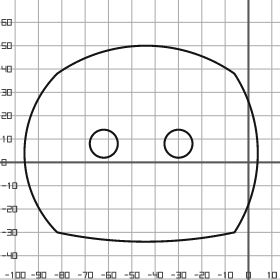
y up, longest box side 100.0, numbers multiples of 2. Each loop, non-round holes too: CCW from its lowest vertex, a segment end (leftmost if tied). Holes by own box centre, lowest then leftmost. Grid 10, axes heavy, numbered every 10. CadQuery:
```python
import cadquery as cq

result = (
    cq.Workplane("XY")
    .moveTo(-82.0, -30.0)
    .threePointArc((-44.0, -34.0), (-6.0, -30.0))
    .threePointArc((4.0, 4.0), (-6.0, 38.0))
    .threePointArc((-44.0, 50.0), (-82.0, 38.0))
    .threePointArc((-96.0, 4.0), (-82.0, -30.0))
    .close()
    .moveTo(-62.0, 8.0)
    .circle(6.0)
    .moveTo(-30.0, 8.0)
    .circle(6.0)
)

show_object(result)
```